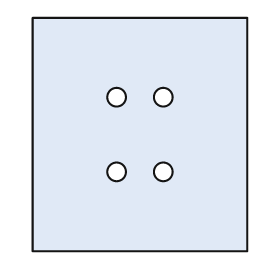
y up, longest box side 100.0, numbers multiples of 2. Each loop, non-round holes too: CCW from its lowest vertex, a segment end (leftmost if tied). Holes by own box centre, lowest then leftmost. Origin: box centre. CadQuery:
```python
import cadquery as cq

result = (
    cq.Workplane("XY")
    .moveTo(-46.0, -50.0)
    .lineTo(46.0, -50.0)
    .lineTo(46.0, 50.0)
    .lineTo(-46.0, 50.0)
    .close()
    .moveTo(-10.0, -16.0)
    .circle(4.0)
    .moveTo(10.0, -16.0)
    .circle(4.0)
    .moveTo(-10.0, 16.0)
    .circle(4.0)
    .moveTo(10.0, 16.0)
    .circle(4.0)
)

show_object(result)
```